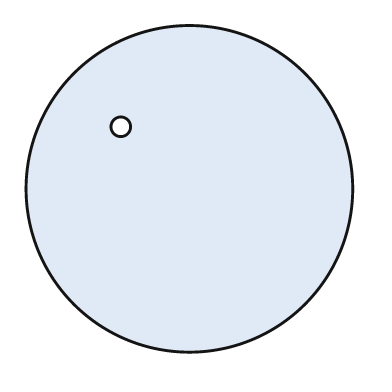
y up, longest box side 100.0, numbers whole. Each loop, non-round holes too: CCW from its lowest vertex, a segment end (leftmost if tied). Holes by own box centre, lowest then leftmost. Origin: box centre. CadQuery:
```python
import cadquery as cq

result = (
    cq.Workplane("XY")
    .moveTo(0.0, 0.0)
    .circle(50.0)
    .moveTo(-21.0, 19.0)
    .circle(3.0)
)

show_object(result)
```